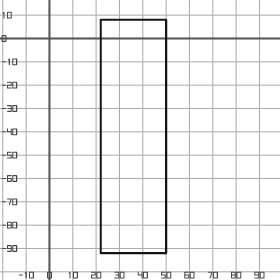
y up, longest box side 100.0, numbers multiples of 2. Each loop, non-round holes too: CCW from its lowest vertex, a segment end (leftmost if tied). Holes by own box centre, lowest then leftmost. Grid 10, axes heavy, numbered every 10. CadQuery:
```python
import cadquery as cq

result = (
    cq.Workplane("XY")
    .moveTo(22.0, -92.0)
    .lineTo(50.0, -92.0)
    .lineTo(50.0, 8.0)
    .lineTo(22.0, 8.0)
    .close()
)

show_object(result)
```